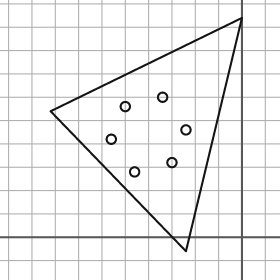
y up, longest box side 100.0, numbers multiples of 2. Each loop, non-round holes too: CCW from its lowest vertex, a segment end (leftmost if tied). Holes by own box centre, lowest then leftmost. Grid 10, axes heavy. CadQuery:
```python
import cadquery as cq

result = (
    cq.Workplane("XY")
    .moveTo(-24.0, -6.0)
    .lineTo(0.0, 94.0)
    .lineTo(-82.0, 54.0)
    .close()
    .moveTo(-46.0, 28.0)
    .circle(2.0)
    .moveTo(-30.0, 32.0)
    .circle(2.0)
    .moveTo(-56.0, 42.0)
    .circle(2.0)
    .moveTo(-24.0, 46.0)
    .circle(2.0)
    .moveTo(-50.0, 56.0)
    .circle(2.0)
    .moveTo(-34.0, 60.0)
    .circle(2.0)
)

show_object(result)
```